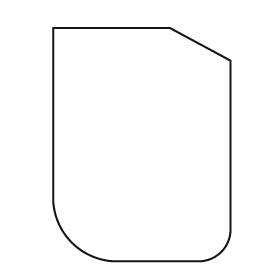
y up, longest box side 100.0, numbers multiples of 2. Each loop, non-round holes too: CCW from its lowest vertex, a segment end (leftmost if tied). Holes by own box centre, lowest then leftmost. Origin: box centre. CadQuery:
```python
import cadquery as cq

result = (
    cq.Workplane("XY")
    .moveTo(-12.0, -50.0)
    .lineTo(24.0, -50.0)
    .threePointArc((34.0, -46.0), (38.0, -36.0))
    .lineTo(38.0, 36.0)
    .lineTo(12.0, 50.0)
    .lineTo(-38.0, 50.0)
    .lineTo(-38.0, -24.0)
    .threePointArc((-30.0, -42.0), (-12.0, -50.0))
    .close()
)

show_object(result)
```